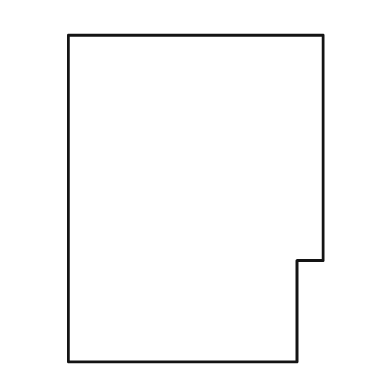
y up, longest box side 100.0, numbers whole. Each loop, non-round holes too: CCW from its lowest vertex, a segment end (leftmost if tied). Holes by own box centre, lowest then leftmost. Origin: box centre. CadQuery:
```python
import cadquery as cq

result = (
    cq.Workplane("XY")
    .moveTo(-39.0, -50.0)
    .lineTo(31.0, -50.0)
    .lineTo(31.0, -19.0)
    .lineTo(39.0, -19.0)
    .lineTo(39.0, 50.0)
    .lineTo(-39.0, 50.0)
    .close()
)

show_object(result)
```